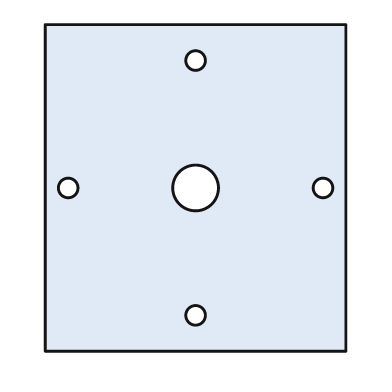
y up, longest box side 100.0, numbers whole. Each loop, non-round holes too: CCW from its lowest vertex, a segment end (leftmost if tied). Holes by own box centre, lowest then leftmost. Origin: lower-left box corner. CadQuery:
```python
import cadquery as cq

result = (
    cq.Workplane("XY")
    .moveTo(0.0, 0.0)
    .lineTo(92.0, 0.0)
    .lineTo(92.0, 100.0)
    .lineTo(0.0, 100.0)
    .close()
    .moveTo(46.0, 11.0)
    .circle(3.0)
    .moveTo(7.0, 50.0)
    .circle(3.0)
    .moveTo(46.0, 50.0)
    .circle(7.0)
    .moveTo(85.0, 50.0)
    .circle(3.0)
    .moveTo(46.0, 89.0)
    .circle(3.0)
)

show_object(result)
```